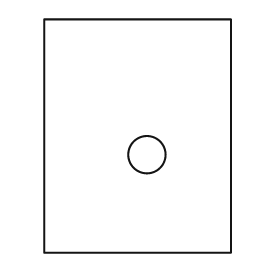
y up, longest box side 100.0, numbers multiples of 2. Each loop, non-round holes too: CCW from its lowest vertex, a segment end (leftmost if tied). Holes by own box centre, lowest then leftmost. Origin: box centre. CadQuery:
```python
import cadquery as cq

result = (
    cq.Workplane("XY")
    .moveTo(-40.0, -50.0)
    .lineTo(40.0, -50.0)
    .lineTo(40.0, 50.0)
    .lineTo(-40.0, 50.0)
    .close()
    .moveTo(4.0, -8.0)
    .circle(8.0)
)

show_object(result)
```